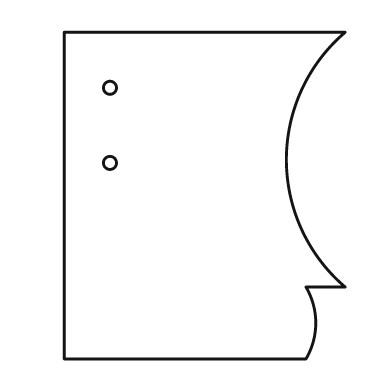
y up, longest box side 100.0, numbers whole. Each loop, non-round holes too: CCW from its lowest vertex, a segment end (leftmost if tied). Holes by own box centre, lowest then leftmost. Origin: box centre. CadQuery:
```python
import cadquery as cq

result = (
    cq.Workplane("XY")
    .moveTo(-43.0, -50.0)
    .lineTo(31.0, -50.0)
    .threePointArc((34.0, -39.0), (31.0, -28.0))
    .lineTo(43.0, -28.0)
    .threePointArc((25.0, 11.0), (43.0, 50.0))
    .lineTo(-43.0, 50.0)
    .close()
    .moveTo(-29.0, 10.0)
    .circle(2.0)
    .moveTo(-29.0, 33.0)
    .circle(2.0)
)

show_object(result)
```